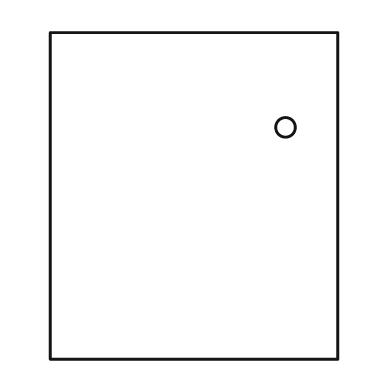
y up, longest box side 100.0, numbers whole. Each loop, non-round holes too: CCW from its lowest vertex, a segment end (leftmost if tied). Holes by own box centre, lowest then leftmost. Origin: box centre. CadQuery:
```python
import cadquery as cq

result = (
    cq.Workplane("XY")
    .moveTo(-44.0, -50.0)
    .lineTo(44.0, -50.0)
    .lineTo(44.0, 50.0)
    .lineTo(-44.0, 50.0)
    .close()
    .moveTo(28.0, 21.0)
    .circle(3.0)
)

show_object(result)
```